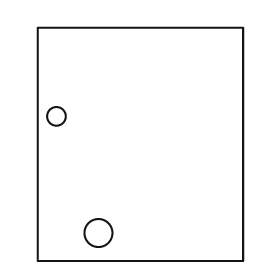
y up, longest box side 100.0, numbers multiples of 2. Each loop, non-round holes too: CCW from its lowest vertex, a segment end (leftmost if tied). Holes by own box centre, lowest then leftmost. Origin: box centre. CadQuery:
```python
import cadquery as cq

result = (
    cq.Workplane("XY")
    .moveTo(-44.0, -50.0)
    .lineTo(44.0, -50.0)
    .lineTo(44.0, 50.0)
    .lineTo(-44.0, 50.0)
    .close()
    .moveTo(-18.0, -38.0)
    .circle(6.0)
    .moveTo(-36.0, 12.0)
    .circle(4.0)
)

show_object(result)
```